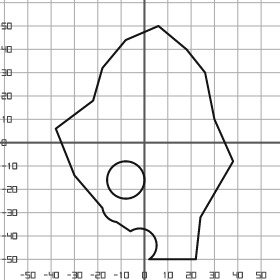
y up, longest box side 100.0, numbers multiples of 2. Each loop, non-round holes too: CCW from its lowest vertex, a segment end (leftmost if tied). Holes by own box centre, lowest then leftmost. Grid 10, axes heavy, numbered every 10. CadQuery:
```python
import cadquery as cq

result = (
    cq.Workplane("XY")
    .moveTo(2.0, -50.0)
    .lineTo(22.0, -50.0)
    .lineTo(24.0, -32.0)
    .lineTo(38.0, -8.0)
    .lineTo(30.0, 10.0)
    .lineTo(26.0, 30.0)
    .lineTo(18.0, 40.0)
    .lineTo(6.0, 50.0)
    .lineTo(-8.0, 44.0)
    .lineTo(-18.0, 32.0)
    .lineTo(-22.0, 18.0)
    .lineTo(-38.0, 6.0)
    .lineTo(-30.0, -14.0)
    .lineTo(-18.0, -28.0)
    .threePointArc((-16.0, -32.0), (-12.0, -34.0))
    .lineTo(-6.0, -38.0)
    .threePointArc((4.0, -40.0), (2.0, -50.0))
    .close()
    .moveTo(-8.0, -16.0)
    .circle(8.0)
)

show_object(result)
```